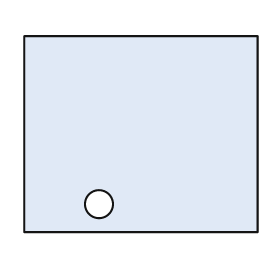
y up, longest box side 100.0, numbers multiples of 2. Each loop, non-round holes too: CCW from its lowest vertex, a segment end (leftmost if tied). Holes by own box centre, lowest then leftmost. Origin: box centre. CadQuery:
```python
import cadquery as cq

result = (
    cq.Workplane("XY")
    .moveTo(-50.0, -42.0)
    .lineTo(50.0, -42.0)
    .lineTo(50.0, 42.0)
    .lineTo(-50.0, 42.0)
    .close()
    .moveTo(-18.0, -30.0)
    .circle(6.0)
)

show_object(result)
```